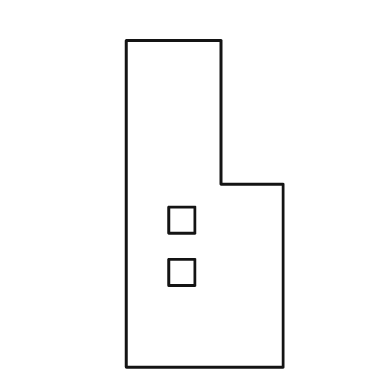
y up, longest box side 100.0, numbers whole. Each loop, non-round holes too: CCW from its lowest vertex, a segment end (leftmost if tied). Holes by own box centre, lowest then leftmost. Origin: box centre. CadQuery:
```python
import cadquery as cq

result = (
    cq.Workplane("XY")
    .moveTo(-24.0, -50.0)
    .lineTo(24.0, -50.0)
    .lineTo(24.0, 6.0)
    .lineTo(5.0, 6.0)
    .lineTo(5.0, 50.0)
    .lineTo(-24.0, 50.0)
    .close()
    .moveTo(-11.0, -25.0)
    .lineTo(-3.0, -25.0)
    .lineTo(-3.0, -17.0)
    .lineTo(-11.0, -17.0)
    .close()
    .moveTo(-11.0, -9.0)
    .lineTo(-3.0, -9.0)
    .lineTo(-3.0, -1.0)
    .lineTo(-11.0, -1.0)
    .close()
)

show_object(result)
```